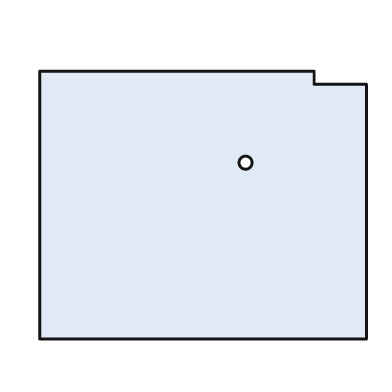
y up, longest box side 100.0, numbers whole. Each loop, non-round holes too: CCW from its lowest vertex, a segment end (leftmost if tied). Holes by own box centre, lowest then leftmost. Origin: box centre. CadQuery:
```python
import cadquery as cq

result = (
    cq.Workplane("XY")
    .moveTo(-50.0, -41.0)
    .lineTo(50.0, -41.0)
    .lineTo(50.0, 37.0)
    .lineTo(34.0, 37.0)
    .lineTo(34.0, 41.0)
    .lineTo(-50.0, 41.0)
    .close()
    .moveTo(13.0, 13.0)
    .circle(2.0)
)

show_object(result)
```